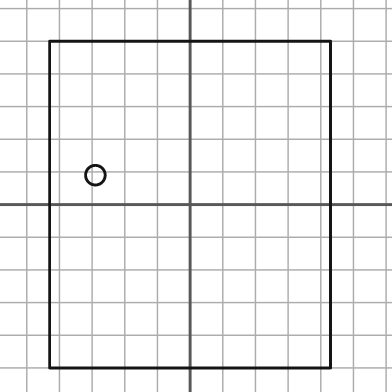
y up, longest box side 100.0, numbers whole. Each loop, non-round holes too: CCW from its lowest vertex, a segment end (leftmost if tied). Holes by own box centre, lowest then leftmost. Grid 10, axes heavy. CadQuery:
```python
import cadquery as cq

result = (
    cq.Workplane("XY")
    .moveTo(-43.0, -50.0)
    .lineTo(43.0, -50.0)
    .lineTo(43.0, 50.0)
    .lineTo(-43.0, 50.0)
    .close()
    .moveTo(-29.0, 9.0)
    .circle(3.0)
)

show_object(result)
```